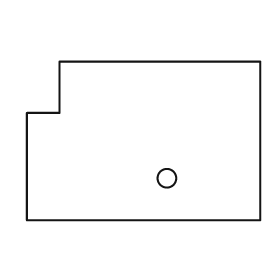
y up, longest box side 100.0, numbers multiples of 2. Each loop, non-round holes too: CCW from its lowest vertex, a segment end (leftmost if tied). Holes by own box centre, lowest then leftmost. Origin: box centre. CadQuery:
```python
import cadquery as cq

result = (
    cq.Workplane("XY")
    .moveTo(-50.0, -34.0)
    .lineTo(50.0, -34.0)
    .lineTo(50.0, 34.0)
    .lineTo(-36.0, 34.0)
    .lineTo(-36.0, 12.0)
    .lineTo(-50.0, 12.0)
    .close()
    .moveTo(10.0, -16.0)
    .circle(4.0)
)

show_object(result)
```